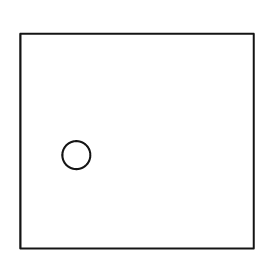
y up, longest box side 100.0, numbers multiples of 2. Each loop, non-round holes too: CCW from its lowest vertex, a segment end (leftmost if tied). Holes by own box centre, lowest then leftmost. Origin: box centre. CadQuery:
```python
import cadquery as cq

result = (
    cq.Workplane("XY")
    .moveTo(-50.0, -46.0)
    .lineTo(50.0, -46.0)
    .lineTo(50.0, 46.0)
    .lineTo(-50.0, 46.0)
    .close()
    .moveTo(-26.0, -6.0)
    .circle(6.0)
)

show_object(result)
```